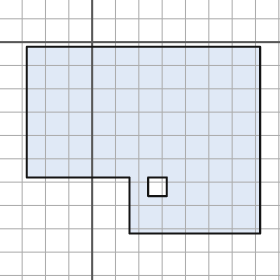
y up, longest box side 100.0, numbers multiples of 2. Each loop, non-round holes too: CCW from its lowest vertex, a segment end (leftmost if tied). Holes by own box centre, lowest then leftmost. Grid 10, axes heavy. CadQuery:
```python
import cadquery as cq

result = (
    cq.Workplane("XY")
    .moveTo(16.0, -82.0)
    .lineTo(72.0, -82.0)
    .lineTo(72.0, -2.0)
    .lineTo(-28.0, -2.0)
    .lineTo(-28.0, -58.0)
    .lineTo(16.0, -58.0)
    .close()
    .moveTo(24.0, -66.0)
    .lineTo(32.0, -66.0)
    .lineTo(32.0, -58.0)
    .lineTo(24.0, -58.0)
    .close()
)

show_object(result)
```